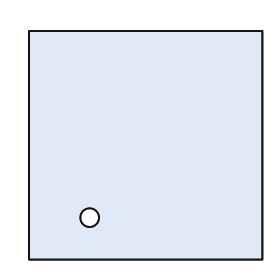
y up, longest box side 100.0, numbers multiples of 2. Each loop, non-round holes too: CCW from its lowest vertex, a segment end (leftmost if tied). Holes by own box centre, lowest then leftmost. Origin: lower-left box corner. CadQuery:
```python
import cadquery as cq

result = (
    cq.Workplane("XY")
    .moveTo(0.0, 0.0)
    .lineTo(100.0, 0.0)
    .lineTo(100.0, 98.0)
    .lineTo(0.0, 98.0)
    .close()
    .moveTo(26.0, 18.0)
    .circle(4.0)
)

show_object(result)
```